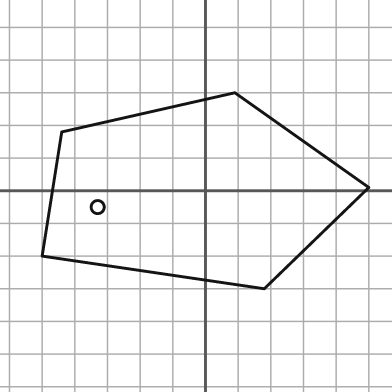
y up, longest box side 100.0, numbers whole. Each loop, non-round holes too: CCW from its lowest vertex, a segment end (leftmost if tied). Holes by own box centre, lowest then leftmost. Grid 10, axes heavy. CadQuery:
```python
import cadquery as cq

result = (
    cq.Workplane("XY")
    .moveTo(18.0, -30.0)
    .lineTo(50.0, 1.0)
    .lineTo(9.0, 30.0)
    .lineTo(-44.0, 18.0)
    .lineTo(-50.0, -20.0)
    .close()
    .moveTo(-33.0, -5.0)
    .circle(2.0)
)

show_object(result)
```